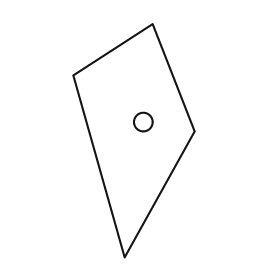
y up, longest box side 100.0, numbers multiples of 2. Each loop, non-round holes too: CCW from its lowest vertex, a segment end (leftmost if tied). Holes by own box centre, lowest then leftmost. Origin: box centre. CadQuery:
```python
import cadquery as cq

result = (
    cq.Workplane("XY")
    .moveTo(-4.0, -50.0)
    .lineTo(26.0, 4.0)
    .lineTo(8.0, 50.0)
    .lineTo(-26.0, 28.0)
    .close()
    .moveTo(4.0, 8.0)
    .circle(4.0)
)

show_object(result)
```